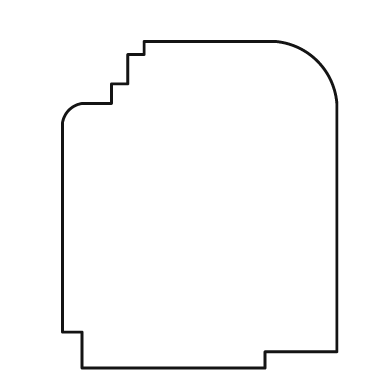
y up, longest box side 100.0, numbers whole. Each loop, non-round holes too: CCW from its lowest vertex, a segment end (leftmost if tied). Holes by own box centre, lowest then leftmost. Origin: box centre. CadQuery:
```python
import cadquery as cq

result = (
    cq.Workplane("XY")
    .moveTo(-36.0, -50.0)
    .lineTo(20.0, -50.0)
    .lineTo(20.0, -45.0)
    .lineTo(42.0, -45.0)
    .lineTo(42.0, 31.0)
    .threePointArc((36.0, 44.0), (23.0, 50.0))
    .lineTo(-17.0, 50.0)
    .lineTo(-17.0, 46.0)
    .lineTo(-22.0, 46.0)
    .lineTo(-22.0, 37.0)
    .lineTo(-27.0, 37.0)
    .lineTo(-27.0, 31.0)
    .lineTo(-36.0, 31.0)
    .threePointArc((-40.0, 29.0), (-42.0, 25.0))
    .lineTo(-42.0, -39.0)
    .lineTo(-36.0, -39.0)
    .close()
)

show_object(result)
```